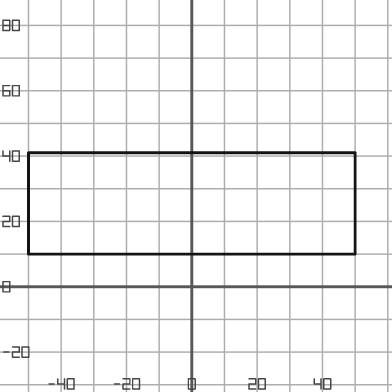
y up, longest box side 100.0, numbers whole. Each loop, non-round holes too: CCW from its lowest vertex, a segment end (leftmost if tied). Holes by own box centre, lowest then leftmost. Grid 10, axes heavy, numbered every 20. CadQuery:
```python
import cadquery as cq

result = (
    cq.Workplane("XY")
    .moveTo(-50.0, 10.0)
    .lineTo(50.0, 10.0)
    .lineTo(50.0, 41.0)
    .lineTo(-50.0, 41.0)
    .close()
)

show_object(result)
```